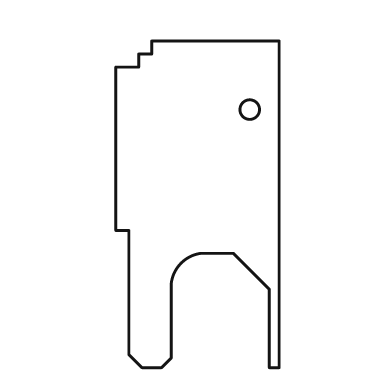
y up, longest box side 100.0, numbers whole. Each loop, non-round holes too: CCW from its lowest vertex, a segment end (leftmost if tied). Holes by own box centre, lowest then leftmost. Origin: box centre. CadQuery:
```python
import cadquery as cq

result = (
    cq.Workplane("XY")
    .moveTo(-17.0, -50.0)
    .lineTo(-11.0, -50.0)
    .lineTo(-8.0, -47.0)
    .lineTo(-8.0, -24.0)
    .threePointArc((-5.0, -18.0), (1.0, -15.0))
    .lineTo(11.0, -15.0)
    .lineTo(22.0, -26.0)
    .lineTo(22.0, -50.0)
    .lineTo(25.0, -50.0)
    .lineTo(25.0, 50.0)
    .lineTo(-14.0, 50.0)
    .lineTo(-14.0, 46.0)
    .lineTo(-18.0, 46.0)
    .lineTo(-18.0, 42.0)
    .lineTo(-25.0, 42.0)
    .lineTo(-25.0, -8.0)
    .lineTo(-21.0, -8.0)
    .lineTo(-21.0, -46.0)
    .close()
    .moveTo(16.0, 29.0)
    .circle(3.0)
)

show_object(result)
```